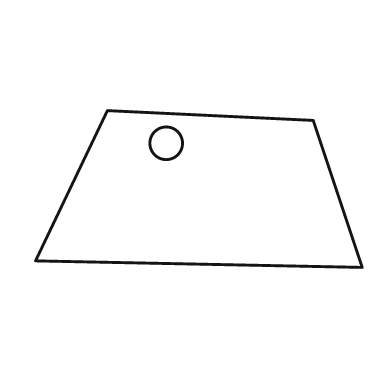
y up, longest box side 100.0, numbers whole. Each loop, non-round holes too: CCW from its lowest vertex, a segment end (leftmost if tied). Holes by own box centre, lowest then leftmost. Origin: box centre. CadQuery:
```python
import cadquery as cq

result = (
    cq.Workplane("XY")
    .moveTo(50.0, -24.0)
    .lineTo(35.0, 21.0)
    .lineTo(-28.0, 24.0)
    .lineTo(-50.0, -22.0)
    .close()
    .moveTo(-10.0, 14.0)
    .circle(5.0)
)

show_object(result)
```